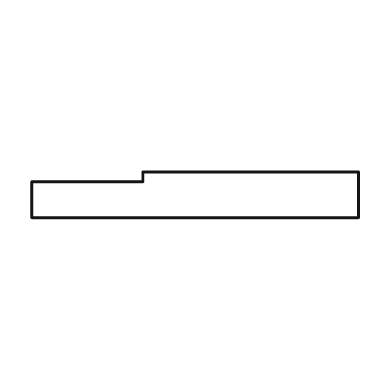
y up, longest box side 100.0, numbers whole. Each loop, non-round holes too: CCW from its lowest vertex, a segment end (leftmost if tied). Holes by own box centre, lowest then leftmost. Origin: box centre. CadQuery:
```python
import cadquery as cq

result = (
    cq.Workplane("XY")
    .moveTo(-50.0, -7.0)
    .lineTo(50.0, -7.0)
    .lineTo(50.0, 7.0)
    .lineTo(-16.0, 7.0)
    .lineTo(-16.0, 4.0)
    .lineTo(-50.0, 4.0)
    .close()
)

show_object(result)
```